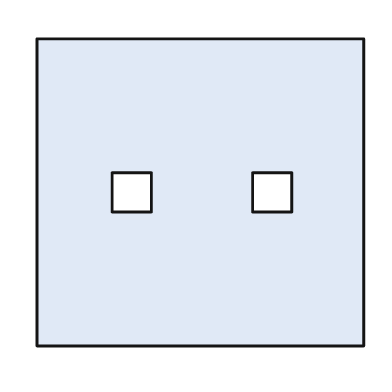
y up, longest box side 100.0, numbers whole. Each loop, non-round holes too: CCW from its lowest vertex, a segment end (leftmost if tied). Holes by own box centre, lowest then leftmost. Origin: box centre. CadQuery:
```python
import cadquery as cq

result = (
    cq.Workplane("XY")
    .moveTo(-50.0, -47.0)
    .lineTo(50.0, -47.0)
    .lineTo(50.0, 47.0)
    .lineTo(-50.0, 47.0)
    .close()
    .moveTo(-27.0, -6.0)
    .lineTo(-15.0, -6.0)
    .lineTo(-15.0, 6.0)
    .lineTo(-27.0, 6.0)
    .close()
    .moveTo(16.0, -6.0)
    .lineTo(28.0, -6.0)
    .lineTo(28.0, 6.0)
    .lineTo(16.0, 6.0)
    .close()
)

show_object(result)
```